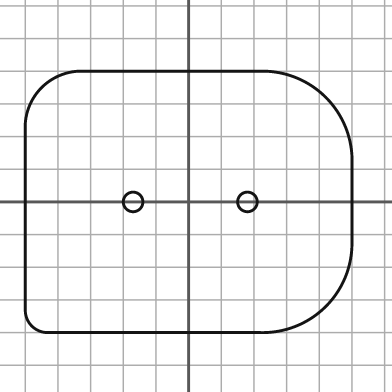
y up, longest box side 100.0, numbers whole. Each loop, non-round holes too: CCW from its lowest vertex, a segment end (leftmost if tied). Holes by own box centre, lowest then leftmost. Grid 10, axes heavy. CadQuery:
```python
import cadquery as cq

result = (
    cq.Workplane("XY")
    .moveTo(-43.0, -40.0)
    .lineTo(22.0, -40.0)
    .threePointArc((42.0, -32.0), (50.0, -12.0))
    .lineTo(50.0, 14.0)
    .threePointArc((42.0, 32.0), (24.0, 40.0))
    .lineTo(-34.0, 40.0)
    .threePointArc((-45.0, 35.0), (-50.0, 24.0))
    .lineTo(-50.0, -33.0)
    .threePointArc((-48.0, -38.0), (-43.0, -40.0))
    .close()
    .moveTo(-17.0, 0.0)
    .circle(3.0)
    .moveTo(18.0, 0.0)
    .circle(3.0)
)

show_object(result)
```